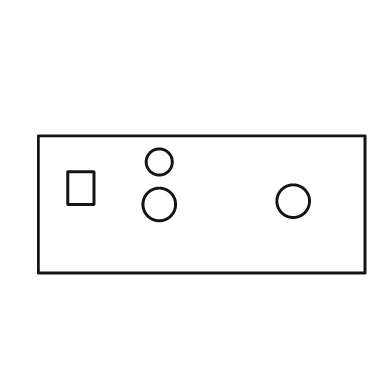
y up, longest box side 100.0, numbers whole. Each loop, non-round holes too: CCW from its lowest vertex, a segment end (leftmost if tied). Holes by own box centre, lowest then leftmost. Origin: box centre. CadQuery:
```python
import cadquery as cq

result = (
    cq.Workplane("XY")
    .moveTo(-50.0, -21.0)
    .lineTo(50.0, -21.0)
    .lineTo(50.0, 21.0)
    .lineTo(-50.0, 21.0)
    .close()
    .moveTo(-13.0, 0.0)
    .circle(5.0)
    .moveTo(28.0, 1.0)
    .circle(5.0)
    .moveTo(-41.0, 0.0)
    .lineTo(-33.0, 0.0)
    .lineTo(-33.0, 10.0)
    .lineTo(-41.0, 10.0)
    .close()
    .moveTo(-13.0, 13.0)
    .circle(4.0)
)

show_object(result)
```